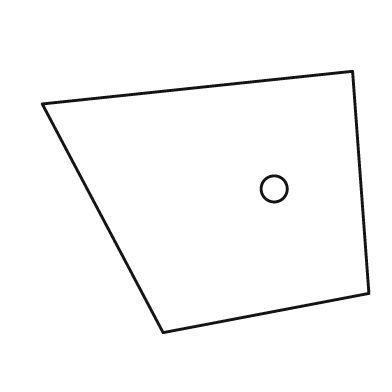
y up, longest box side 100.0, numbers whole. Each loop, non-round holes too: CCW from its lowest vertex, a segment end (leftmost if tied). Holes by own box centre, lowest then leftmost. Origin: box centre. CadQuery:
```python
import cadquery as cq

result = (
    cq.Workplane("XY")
    .moveTo(-13.0, -40.0)
    .lineTo(50.0, -28.0)
    .lineTo(45.0, 40.0)
    .lineTo(-50.0, 30.0)
    .close()
    .moveTo(21.0, 4.0)
    .circle(4.0)
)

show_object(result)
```